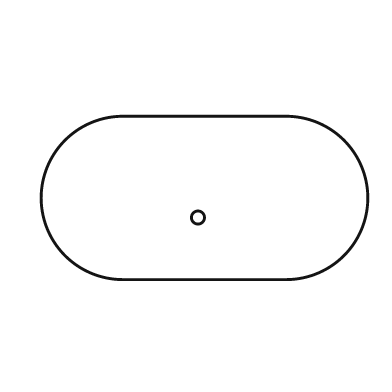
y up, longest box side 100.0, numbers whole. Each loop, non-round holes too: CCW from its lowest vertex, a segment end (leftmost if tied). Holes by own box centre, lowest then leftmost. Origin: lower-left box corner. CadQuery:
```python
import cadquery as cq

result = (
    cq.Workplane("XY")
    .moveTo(25.0, 0.0)
    .lineTo(75.0, 0.0)
    .threePointArc((100.0, 25.0), (75.0, 50.0))
    .lineTo(25.0, 50.0)
    .threePointArc((0.0, 25.0), (25.0, 0.0))
    .close()
    .moveTo(48.0, 19.0)
    .circle(2.0)
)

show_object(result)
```